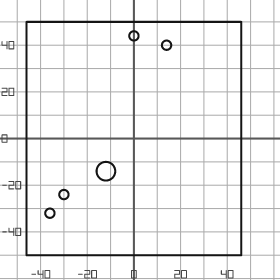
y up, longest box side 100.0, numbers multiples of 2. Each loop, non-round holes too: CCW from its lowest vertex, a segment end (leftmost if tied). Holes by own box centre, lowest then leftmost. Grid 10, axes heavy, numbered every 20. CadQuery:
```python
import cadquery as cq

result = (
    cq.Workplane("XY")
    .moveTo(-46.0, -50.0)
    .lineTo(46.0, -50.0)
    .lineTo(46.0, 50.0)
    .lineTo(-46.0, 50.0)
    .close()
    .moveTo(-36.0, -32.0)
    .circle(2.0)
    .moveTo(-30.0, -24.0)
    .circle(2.0)
    .moveTo(-12.0, -14.0)
    .circle(4.0)
    .moveTo(14.0, 40.0)
    .circle(2.0)
    .moveTo(0.0, 44.0)
    .circle(2.0)
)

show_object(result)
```